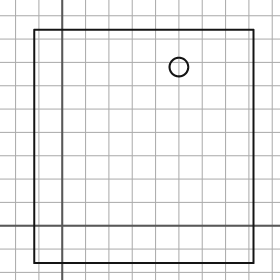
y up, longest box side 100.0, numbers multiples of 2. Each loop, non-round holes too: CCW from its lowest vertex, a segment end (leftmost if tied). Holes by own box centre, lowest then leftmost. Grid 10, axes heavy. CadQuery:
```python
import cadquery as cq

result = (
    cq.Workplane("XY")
    .moveTo(-12.0, -16.0)
    .lineTo(82.0, -16.0)
    .lineTo(82.0, 84.0)
    .lineTo(-12.0, 84.0)
    .close()
    .moveTo(50.0, 68.0)
    .circle(4.0)
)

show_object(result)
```